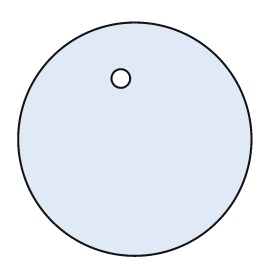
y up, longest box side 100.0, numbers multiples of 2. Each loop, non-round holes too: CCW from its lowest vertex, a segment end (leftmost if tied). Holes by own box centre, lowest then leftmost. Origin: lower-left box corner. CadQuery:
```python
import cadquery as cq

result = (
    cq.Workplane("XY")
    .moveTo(50.0, 50.0)
    .circle(50.0)
    .moveTo(44.0, 76.0)
    .circle(4.0)
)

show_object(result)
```